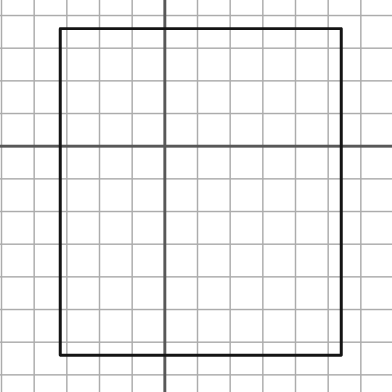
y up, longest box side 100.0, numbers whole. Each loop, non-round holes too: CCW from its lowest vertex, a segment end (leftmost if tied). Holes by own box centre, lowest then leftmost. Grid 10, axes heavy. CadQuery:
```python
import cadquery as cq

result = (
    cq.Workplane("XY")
    .moveTo(-32.0, -64.0)
    .lineTo(54.0, -64.0)
    .lineTo(54.0, 36.0)
    .lineTo(-32.0, 36.0)
    .close()
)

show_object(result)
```